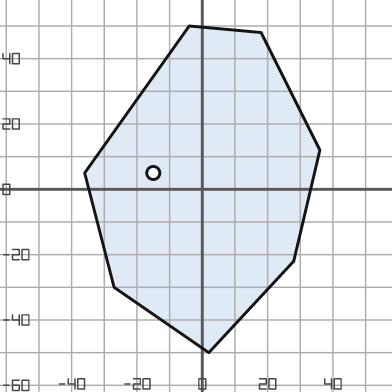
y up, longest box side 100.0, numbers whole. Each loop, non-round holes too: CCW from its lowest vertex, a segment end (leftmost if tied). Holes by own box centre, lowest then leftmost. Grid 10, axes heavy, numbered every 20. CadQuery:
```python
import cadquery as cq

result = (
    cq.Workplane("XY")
    .moveTo(2.0, -50.0)
    .lineTo(28.0, -22.0)
    .lineTo(36.0, 12.0)
    .lineTo(18.0, 48.0)
    .lineTo(-4.0, 50.0)
    .lineTo(-36.0, 5.0)
    .lineTo(-27.0, -30.0)
    .close()
    .moveTo(-15.0, 5.0)
    .circle(2.0)
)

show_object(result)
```